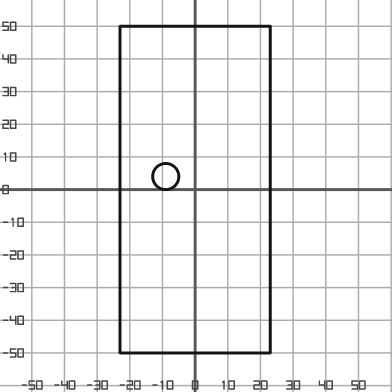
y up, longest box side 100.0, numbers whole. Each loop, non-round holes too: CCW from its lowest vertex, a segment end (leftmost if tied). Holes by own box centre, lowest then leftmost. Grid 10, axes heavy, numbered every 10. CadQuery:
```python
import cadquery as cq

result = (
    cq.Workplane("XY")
    .moveTo(-23.0, -50.0)
    .lineTo(23.0, -50.0)
    .lineTo(23.0, 50.0)
    .lineTo(-23.0, 50.0)
    .close()
    .moveTo(-9.0, 4.0)
    .circle(4.0)
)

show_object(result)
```